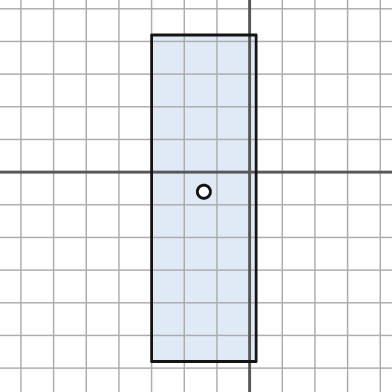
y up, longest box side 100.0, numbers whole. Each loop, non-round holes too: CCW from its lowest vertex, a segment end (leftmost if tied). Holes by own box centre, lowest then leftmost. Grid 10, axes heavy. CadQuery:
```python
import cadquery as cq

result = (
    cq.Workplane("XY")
    .moveTo(-30.0, -58.0)
    .lineTo(2.0, -58.0)
    .lineTo(2.0, 42.0)
    .lineTo(-30.0, 42.0)
    .close()
    .moveTo(-14.0, -6.0)
    .circle(2.0)
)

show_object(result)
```